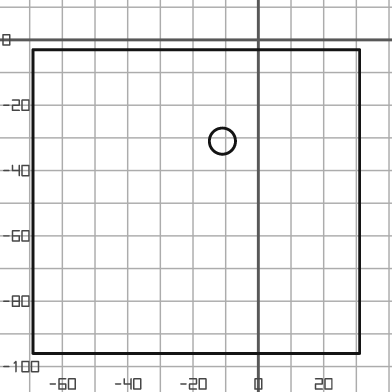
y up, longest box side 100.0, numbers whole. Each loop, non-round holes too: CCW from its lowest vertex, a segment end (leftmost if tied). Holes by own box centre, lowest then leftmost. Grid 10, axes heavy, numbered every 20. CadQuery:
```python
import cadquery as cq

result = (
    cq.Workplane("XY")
    .moveTo(-69.0, -96.0)
    .lineTo(31.0, -96.0)
    .lineTo(31.0, -3.0)
    .lineTo(-69.0, -3.0)
    .close()
    .moveTo(-11.0, -31.0)
    .circle(4.0)
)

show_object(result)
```